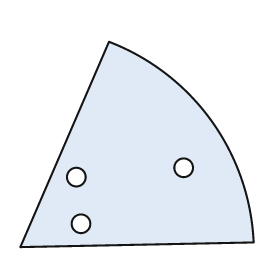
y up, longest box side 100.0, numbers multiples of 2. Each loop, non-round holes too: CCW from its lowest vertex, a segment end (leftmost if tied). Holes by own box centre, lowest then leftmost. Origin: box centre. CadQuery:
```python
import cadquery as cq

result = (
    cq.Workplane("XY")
    .moveTo(-50.0, -44.0)
    .lineTo(50.0, -42.0)
    .threePointArc((32.0, 10.0), (-12.0, 44.0))
    .close()
    .moveTo(-24.0, -34.0)
    .circle(4.0)
    .moveTo(-26.0, -14.0)
    .circle(4.0)
    .moveTo(20.0, -10.0)
    .circle(4.0)
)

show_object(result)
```